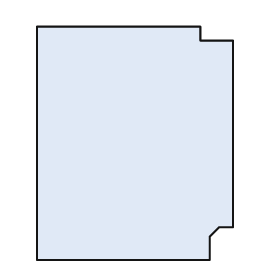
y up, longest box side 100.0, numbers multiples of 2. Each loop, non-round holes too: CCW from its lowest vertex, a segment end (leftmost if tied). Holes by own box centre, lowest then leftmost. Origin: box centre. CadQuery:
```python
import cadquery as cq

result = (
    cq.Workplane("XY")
    .moveTo(-42.0, -50.0)
    .lineTo(32.0, -50.0)
    .lineTo(32.0, -40.0)
    .lineTo(36.0, -36.0)
    .lineTo(42.0, -36.0)
    .lineTo(42.0, 44.0)
    .lineTo(28.0, 44.0)
    .lineTo(28.0, 50.0)
    .lineTo(-42.0, 50.0)
    .close()
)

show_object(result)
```